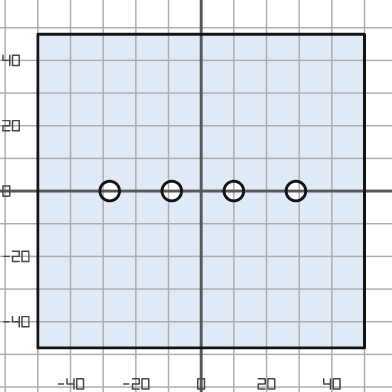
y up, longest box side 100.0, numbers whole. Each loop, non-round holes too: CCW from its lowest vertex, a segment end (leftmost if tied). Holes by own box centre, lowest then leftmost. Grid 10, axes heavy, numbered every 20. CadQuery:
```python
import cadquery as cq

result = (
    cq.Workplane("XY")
    .moveTo(-50.0, -48.0)
    .lineTo(50.0, -48.0)
    .lineTo(50.0, 48.0)
    .lineTo(-50.0, 48.0)
    .close()
    .moveTo(-28.0, 0.0)
    .circle(3.0)
    .moveTo(-9.0, 0.0)
    .circle(3.0)
    .moveTo(10.0, 0.0)
    .circle(3.0)
    .moveTo(29.0, 0.0)
    .circle(3.0)
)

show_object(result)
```